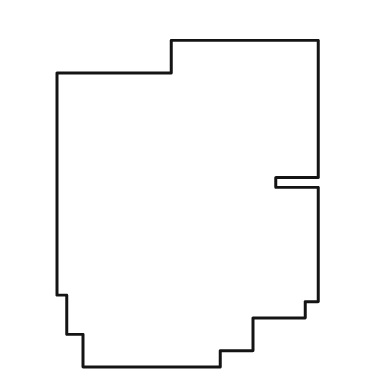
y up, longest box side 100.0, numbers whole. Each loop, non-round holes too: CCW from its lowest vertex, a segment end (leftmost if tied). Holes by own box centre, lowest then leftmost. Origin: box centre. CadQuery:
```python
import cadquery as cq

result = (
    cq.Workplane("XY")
    .moveTo(-32.0, -50.0)
    .lineTo(10.0, -50.0)
    .lineTo(10.0, -45.0)
    .lineTo(20.0, -45.0)
    .lineTo(20.0, -35.0)
    .lineTo(36.0, -35.0)
    .lineTo(36.0, -30.0)
    .lineTo(40.0, -30.0)
    .lineTo(40.0, 5.0)
    .lineTo(27.0, 5.0)
    .lineTo(27.0, 8.0)
    .lineTo(40.0, 8.0)
    .lineTo(40.0, 50.0)
    .lineTo(-5.0, 50.0)
    .lineTo(-5.0, 40.0)
    .lineTo(-40.0, 40.0)
    .lineTo(-40.0, -28.0)
    .lineTo(-37.0, -28.0)
    .lineTo(-37.0, -40.0)
    .lineTo(-32.0, -40.0)
    .close()
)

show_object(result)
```